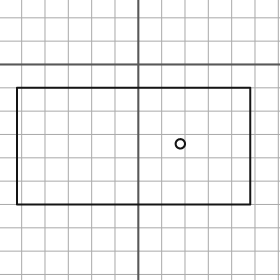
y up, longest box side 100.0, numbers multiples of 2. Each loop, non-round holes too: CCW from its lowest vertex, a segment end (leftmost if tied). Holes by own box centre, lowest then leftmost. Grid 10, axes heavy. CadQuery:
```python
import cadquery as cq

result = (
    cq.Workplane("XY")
    .moveTo(-52.0, -60.0)
    .lineTo(48.0, -60.0)
    .lineTo(48.0, -10.0)
    .lineTo(-52.0, -10.0)
    .close()
    .moveTo(18.0, -34.0)
    .circle(2.0)
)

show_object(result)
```